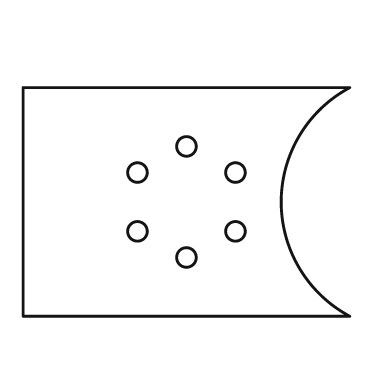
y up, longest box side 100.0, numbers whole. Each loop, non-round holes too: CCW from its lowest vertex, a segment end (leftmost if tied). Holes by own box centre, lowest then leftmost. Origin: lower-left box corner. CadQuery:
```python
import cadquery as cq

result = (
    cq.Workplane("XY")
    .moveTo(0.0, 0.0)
    .lineTo(100.0, 0.0)
    .threePointArc((79.0, 35.0), (100.0, 70.0))
    .lineTo(0.0, 70.0)
    .close()
    .moveTo(50.0, 18.0)
    .circle(3.0)
    .moveTo(35.0, 26.0)
    .circle(3.0)
    .moveTo(65.0, 26.0)
    .circle(3.0)
    .moveTo(35.0, 44.0)
    .circle(3.0)
    .moveTo(65.0, 44.0)
    .circle(3.0)
    .moveTo(50.0, 52.0)
    .circle(3.0)
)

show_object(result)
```